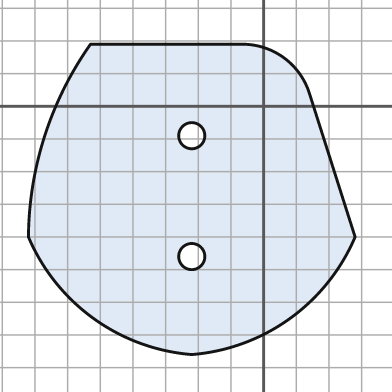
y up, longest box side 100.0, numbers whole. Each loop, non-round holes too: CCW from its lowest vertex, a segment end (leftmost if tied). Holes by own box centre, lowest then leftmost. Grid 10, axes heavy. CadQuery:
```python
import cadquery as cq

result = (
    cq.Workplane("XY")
    .moveTo(-22.0, -76.0)
    .threePointArc((8.0, -65.0), (28.0, -40.0))
    .lineTo(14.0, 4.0)
    .threePointArc((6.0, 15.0), (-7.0, 19.0))
    .lineTo(-53.0, 19.0)
    .threePointArc((-67.0, -9.0), (-72.0, -40.0))
    .threePointArc((-52.0, -65.0), (-22.0, -76.0))
    .close()
    .moveTo(-22.0, -46.0)
    .circle(4.0)
    .moveTo(-22.0, -9.0)
    .circle(4.0)
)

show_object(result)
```